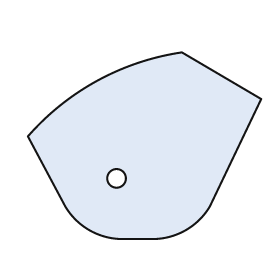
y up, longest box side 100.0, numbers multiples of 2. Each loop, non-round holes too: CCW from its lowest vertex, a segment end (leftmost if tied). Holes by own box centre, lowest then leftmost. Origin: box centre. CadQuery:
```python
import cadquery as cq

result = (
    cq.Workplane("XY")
    .moveTo(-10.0, -40.0)
    .lineTo(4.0, -40.0)
    .threePointArc((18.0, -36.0), (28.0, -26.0))
    .lineTo(50.0, 20.0)
    .lineTo(16.0, 40.0)
    .threePointArc((-20.0, 28.0), (-50.0, 4.0))
    .lineTo(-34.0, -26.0)
    .threePointArc((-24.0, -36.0), (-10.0, -40.0))
    .close()
    .moveTo(-12.0, -14.0)
    .circle(4.0)
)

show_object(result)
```